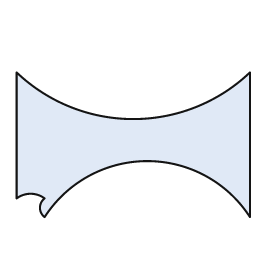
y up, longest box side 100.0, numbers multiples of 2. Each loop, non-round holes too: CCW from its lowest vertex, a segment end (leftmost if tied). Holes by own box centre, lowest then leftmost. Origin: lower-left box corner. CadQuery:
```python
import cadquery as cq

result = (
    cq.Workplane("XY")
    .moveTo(12.0, 0.0)
    .threePointArc((56.0, 24.0), (100.0, 0.0))
    .lineTo(100.0, 62.0)
    .threePointArc((50.0, 42.0), (0.0, 62.0))
    .lineTo(0.0, 8.0)
    .threePointArc((6.0, 10.0), (12.0, 8.0))
    .threePointArc((10.0, 4.0), (12.0, 0.0))
    .close()
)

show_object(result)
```